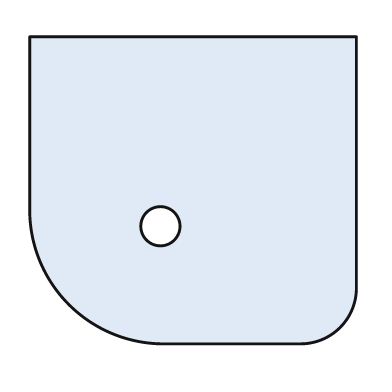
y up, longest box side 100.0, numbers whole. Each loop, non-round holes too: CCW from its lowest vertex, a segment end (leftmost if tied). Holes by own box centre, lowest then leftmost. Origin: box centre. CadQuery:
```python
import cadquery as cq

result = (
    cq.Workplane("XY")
    .moveTo(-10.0, -47.0)
    .lineTo(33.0, -47.0)
    .threePointArc((45.0, -42.0), (50.0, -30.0))
    .lineTo(50.0, 47.0)
    .lineTo(-50.0, 47.0)
    .lineTo(-50.0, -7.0)
    .threePointArc((-38.0, -35.0), (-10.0, -47.0))
    .close()
    .moveTo(-10.0, -11.0)
    .circle(6.0)
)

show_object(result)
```